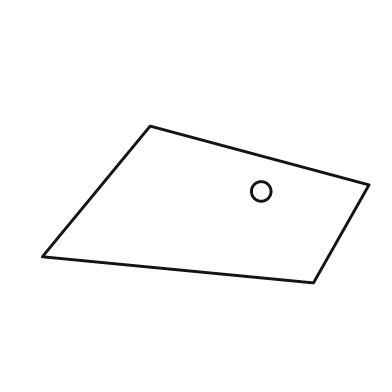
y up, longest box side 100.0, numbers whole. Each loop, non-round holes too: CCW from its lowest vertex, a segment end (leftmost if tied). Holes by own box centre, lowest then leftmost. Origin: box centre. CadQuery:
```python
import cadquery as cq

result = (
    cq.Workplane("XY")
    .moveTo(33.0, -24.0)
    .lineTo(50.0, 6.0)
    .lineTo(-17.0, 24.0)
    .lineTo(-50.0, -16.0)
    .close()
    .moveTo(17.0, 4.0)
    .circle(3.0)
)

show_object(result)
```